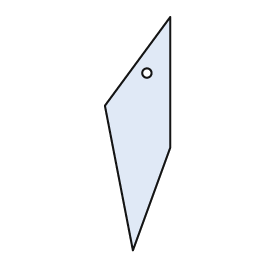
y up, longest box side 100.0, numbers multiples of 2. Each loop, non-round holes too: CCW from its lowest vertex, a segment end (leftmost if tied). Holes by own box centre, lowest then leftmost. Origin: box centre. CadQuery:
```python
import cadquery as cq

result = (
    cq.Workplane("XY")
    .moveTo(-2.0, -50.0)
    .lineTo(14.0, -6.0)
    .lineTo(14.0, 50.0)
    .lineTo(-14.0, 12.0)
    .close()
    .moveTo(4.0, 26.0)
    .circle(2.0)
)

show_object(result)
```